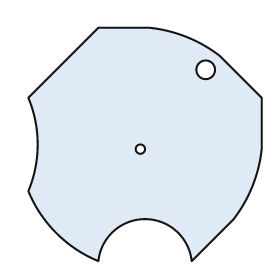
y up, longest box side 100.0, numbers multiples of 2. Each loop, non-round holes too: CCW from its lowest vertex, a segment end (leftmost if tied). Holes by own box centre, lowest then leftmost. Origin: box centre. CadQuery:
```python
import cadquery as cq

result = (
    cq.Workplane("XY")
    .moveTo(-20.0, -50.0)
    .threePointArc((0.0, -32.0), (20.0, -50.0))
    .lineTo(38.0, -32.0)
    .threePointArc((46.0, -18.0), (50.0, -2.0))
    .lineTo(50.0, 20.0)
    .lineTo(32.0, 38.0)
    .threePointArc((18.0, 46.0), (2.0, 50.0))
    .lineTo(-20.0, 50.0)
    .lineTo(-50.0, 20.0)
    .threePointArc((-46.0, 0.0), (-50.0, -20.0))
    .threePointArc((-38.0, -38.0), (-20.0, -50.0))
    .close()
    .moveTo(-2.0, -2.0)
    .circle(2.0)
    .moveTo(26.0, 32.0)
    .circle(4.0)
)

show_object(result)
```